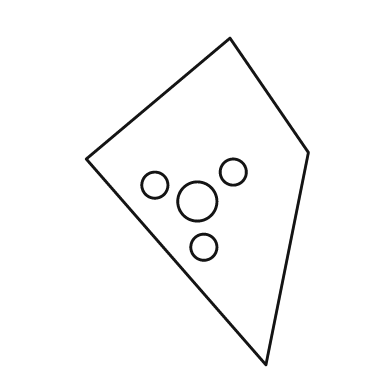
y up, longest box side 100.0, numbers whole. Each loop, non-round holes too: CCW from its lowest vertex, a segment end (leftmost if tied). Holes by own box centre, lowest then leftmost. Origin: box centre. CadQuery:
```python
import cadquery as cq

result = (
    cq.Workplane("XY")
    .moveTo(21.0, -50.0)
    .lineTo(34.0, 15.0)
    .lineTo(10.0, 50.0)
    .lineTo(-34.0, 13.0)
    .close()
    .moveTo(2.0, -14.0)
    .circle(4.0)
    .moveTo(0.0, 0.0)
    .circle(6.0)
    .moveTo(-13.0, 5.0)
    .circle(4.0)
    .moveTo(11.0, 9.0)
    .circle(4.0)
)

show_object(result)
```